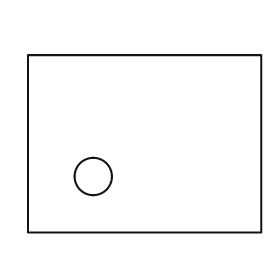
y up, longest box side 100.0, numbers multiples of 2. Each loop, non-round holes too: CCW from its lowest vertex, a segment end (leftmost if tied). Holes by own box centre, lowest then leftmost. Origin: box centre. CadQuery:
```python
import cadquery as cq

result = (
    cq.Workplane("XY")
    .moveTo(-50.0, -38.0)
    .lineTo(50.0, -38.0)
    .lineTo(50.0, 38.0)
    .lineTo(-50.0, 38.0)
    .close()
    .moveTo(-22.0, -14.0)
    .circle(8.0)
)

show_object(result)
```